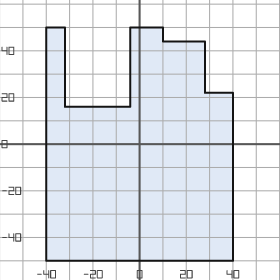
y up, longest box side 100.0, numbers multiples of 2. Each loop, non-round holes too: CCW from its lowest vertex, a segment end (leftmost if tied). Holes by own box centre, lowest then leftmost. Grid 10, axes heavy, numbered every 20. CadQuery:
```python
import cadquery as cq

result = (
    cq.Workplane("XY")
    .moveTo(-40.0, -50.0)
    .lineTo(40.0, -50.0)
    .lineTo(40.0, 22.0)
    .lineTo(28.0, 22.0)
    .lineTo(28.0, 44.0)
    .lineTo(10.0, 44.0)
    .lineTo(10.0, 50.0)
    .lineTo(-4.0, 50.0)
    .lineTo(-4.0, 16.0)
    .lineTo(-32.0, 16.0)
    .lineTo(-32.0, 50.0)
    .lineTo(-40.0, 50.0)
    .close()
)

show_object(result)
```